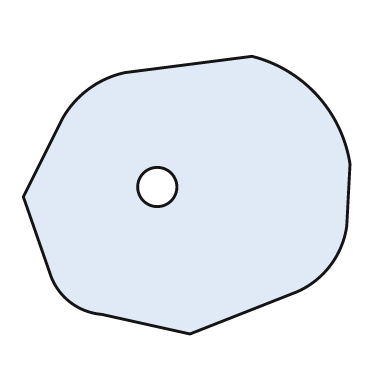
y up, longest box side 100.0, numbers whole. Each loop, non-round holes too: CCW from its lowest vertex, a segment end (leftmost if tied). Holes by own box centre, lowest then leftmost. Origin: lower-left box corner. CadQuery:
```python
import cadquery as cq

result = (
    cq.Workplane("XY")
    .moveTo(51.0, 0.0)
    .lineTo(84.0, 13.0)
    .threePointArc((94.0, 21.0), (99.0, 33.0))
    .lineTo(100.0, 52.0)
    .threePointArc((90.0, 73.0), (70.0, 85.0))
    .lineTo(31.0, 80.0)
    .threePointArc((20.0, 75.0), (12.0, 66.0))
    .lineTo(0.0, 42.0)
    .lineTo(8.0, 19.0)
    .threePointArc((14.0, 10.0), (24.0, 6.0))
    .close()
    .moveTo(41.0, 45.0)
    .circle(6.0)
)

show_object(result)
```